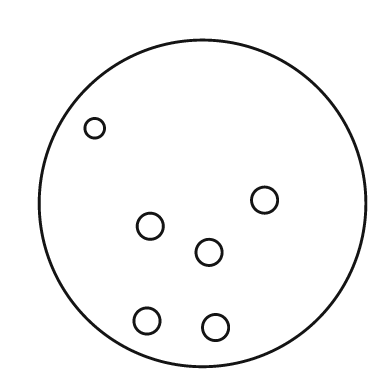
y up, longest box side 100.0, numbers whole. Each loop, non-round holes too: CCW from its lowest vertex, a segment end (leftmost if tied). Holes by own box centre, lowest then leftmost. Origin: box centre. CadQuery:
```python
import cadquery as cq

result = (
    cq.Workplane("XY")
    .moveTo(0.0, 0.0)
    .circle(50.0)
    .moveTo(4.0, -38.0)
    .circle(4.0)
    .moveTo(-17.0, -36.0)
    .circle(4.0)
    .moveTo(2.0, -15.0)
    .circle(4.0)
    .moveTo(-16.0, -7.0)
    .circle(4.0)
    .moveTo(19.0, 1.0)
    .circle(4.0)
    .moveTo(-33.0, 23.0)
    .circle(3.0)
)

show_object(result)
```